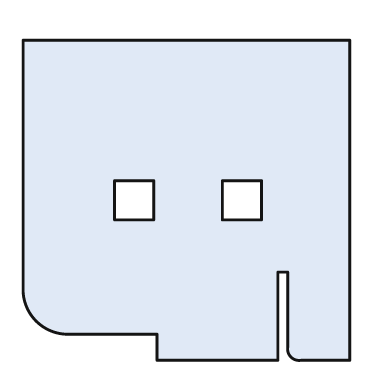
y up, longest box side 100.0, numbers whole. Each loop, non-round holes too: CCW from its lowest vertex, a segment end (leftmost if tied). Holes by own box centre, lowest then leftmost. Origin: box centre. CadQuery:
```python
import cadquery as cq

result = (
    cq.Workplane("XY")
    .moveTo(-9.0, -49.0)
    .lineTo(28.0, -49.0)
    .lineTo(28.0, -22.0)
    .lineTo(31.0, -22.0)
    .lineTo(31.0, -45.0)
    .threePointArc((32.0, -48.0), (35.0, -49.0))
    .lineTo(50.0, -49.0)
    .lineTo(50.0, 49.0)
    .lineTo(-50.0, 49.0)
    .lineTo(-50.0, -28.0)
    .threePointArc((-46.0, -37.0), (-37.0, -41.0))
    .lineTo(-9.0, -41.0)
    .close()
    .moveTo(-22.0, -6.0)
    .lineTo(-10.0, -6.0)
    .lineTo(-10.0, 6.0)
    .lineTo(-22.0, 6.0)
    .close()
    .moveTo(11.0, -6.0)
    .lineTo(23.0, -6.0)
    .lineTo(23.0, 6.0)
    .lineTo(11.0, 6.0)
    .close()
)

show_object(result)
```